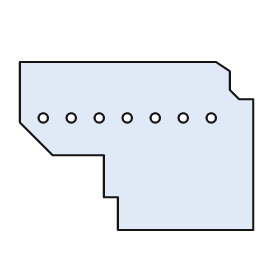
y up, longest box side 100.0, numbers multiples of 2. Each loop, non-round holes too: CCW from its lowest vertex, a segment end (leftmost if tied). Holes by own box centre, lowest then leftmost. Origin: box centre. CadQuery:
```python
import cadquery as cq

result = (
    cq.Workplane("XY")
    .moveTo(-8.0, -36.0)
    .lineTo(50.0, -36.0)
    .lineTo(50.0, 20.0)
    .lineTo(44.0, 20.0)
    .lineTo(40.0, 24.0)
    .lineTo(40.0, 32.0)
    .lineTo(34.0, 36.0)
    .lineTo(-50.0, 36.0)
    .lineTo(-50.0, 10.0)
    .lineTo(-36.0, -4.0)
    .lineTo(-14.0, -4.0)
    .lineTo(-14.0, -22.0)
    .lineTo(-8.0, -22.0)
    .close()
    .moveTo(-40.0, 12.0)
    .circle(2.0)
    .moveTo(-28.0, 12.0)
    .circle(2.0)
    .moveTo(-16.0, 12.0)
    .circle(2.0)
    .moveTo(-4.0, 12.0)
    .circle(2.0)
    .moveTo(8.0, 12.0)
    .circle(2.0)
    .moveTo(20.0, 12.0)
    .circle(2.0)
    .moveTo(32.0, 12.0)
    .circle(2.0)
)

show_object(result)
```